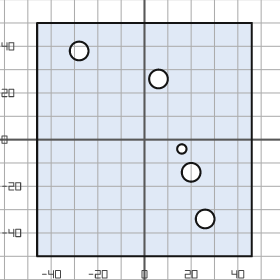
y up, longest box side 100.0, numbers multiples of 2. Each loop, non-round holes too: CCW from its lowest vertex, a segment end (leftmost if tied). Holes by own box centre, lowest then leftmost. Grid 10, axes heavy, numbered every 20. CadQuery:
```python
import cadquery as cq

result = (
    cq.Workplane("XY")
    .moveTo(-46.0, -50.0)
    .lineTo(46.0, -50.0)
    .lineTo(46.0, 50.0)
    .lineTo(-46.0, 50.0)
    .close()
    .moveTo(26.0, -34.0)
    .circle(4.0)
    .moveTo(20.0, -14.0)
    .circle(4.0)
    .moveTo(16.0, -4.0)
    .circle(2.0)
    .moveTo(6.0, 26.0)
    .circle(4.0)
    .moveTo(-28.0, 38.0)
    .circle(4.0)
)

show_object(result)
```